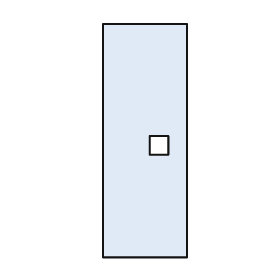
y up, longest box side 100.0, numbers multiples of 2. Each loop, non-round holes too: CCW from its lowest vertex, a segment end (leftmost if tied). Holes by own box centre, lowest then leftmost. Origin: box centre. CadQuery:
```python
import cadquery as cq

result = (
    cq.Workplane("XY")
    .moveTo(-18.0, -50.0)
    .lineTo(18.0, -50.0)
    .lineTo(18.0, 50.0)
    .lineTo(-18.0, 50.0)
    .close()
    .moveTo(2.0, -6.0)
    .lineTo(10.0, -6.0)
    .lineTo(10.0, 2.0)
    .lineTo(2.0, 2.0)
    .close()
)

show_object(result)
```